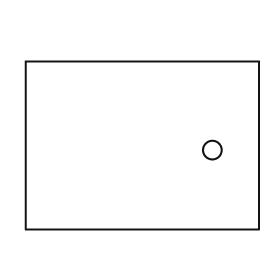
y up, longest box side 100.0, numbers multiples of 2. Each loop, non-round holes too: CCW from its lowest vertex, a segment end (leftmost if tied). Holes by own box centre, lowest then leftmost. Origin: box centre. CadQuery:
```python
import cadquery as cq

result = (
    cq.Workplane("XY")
    .moveTo(-50.0, -36.0)
    .lineTo(50.0, -36.0)
    .lineTo(50.0, 36.0)
    .lineTo(-50.0, 36.0)
    .close()
    .moveTo(30.0, -2.0)
    .circle(4.0)
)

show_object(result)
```